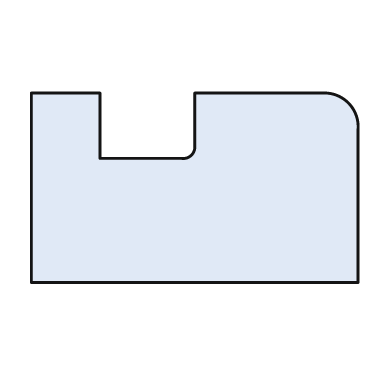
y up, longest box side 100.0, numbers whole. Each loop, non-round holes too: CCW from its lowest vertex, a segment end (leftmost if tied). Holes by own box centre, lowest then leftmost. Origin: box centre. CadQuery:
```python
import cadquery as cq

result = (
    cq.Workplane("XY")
    .moveTo(-50.0, -29.0)
    .lineTo(50.0, -29.0)
    .lineTo(50.0, 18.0)
    .threePointArc((47.0, 26.0), (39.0, 29.0))
    .lineTo(0.0, 29.0)
    .lineTo(0.0, 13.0)
    .threePointArc((-1.0, 10.0), (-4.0, 9.0))
    .lineTo(-29.0, 9.0)
    .lineTo(-29.0, 29.0)
    .lineTo(-50.0, 29.0)
    .close()
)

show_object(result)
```